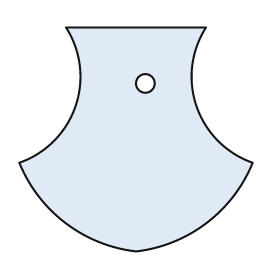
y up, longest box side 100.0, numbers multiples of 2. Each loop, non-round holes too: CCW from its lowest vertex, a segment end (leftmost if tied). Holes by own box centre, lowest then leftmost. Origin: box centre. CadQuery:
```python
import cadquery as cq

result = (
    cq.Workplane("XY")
    .moveTo(0.0, -48.0)
    .threePointArc((30.0, -36.0), (50.0, -10.0))
    .threePointArc((26.0, 14.0), (30.0, 48.0))
    .lineTo(-30.0, 48.0)
    .threePointArc((-26.0, 14.0), (-50.0, -10.0))
    .threePointArc((-30.0, -36.0), (0.0, -48.0))
    .close()
    .moveTo(4.0, 24.0)
    .circle(4.0)
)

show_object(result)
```